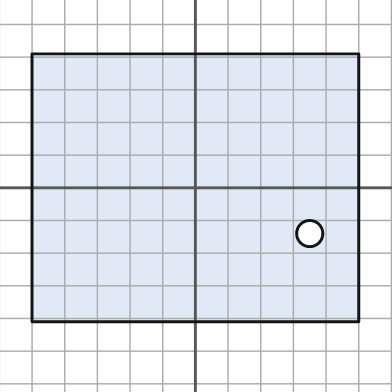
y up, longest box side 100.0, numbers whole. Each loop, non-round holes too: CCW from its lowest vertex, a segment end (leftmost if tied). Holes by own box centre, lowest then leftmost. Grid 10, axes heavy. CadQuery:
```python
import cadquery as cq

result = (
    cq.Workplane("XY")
    .moveTo(-50.0, -41.0)
    .lineTo(50.0, -41.0)
    .lineTo(50.0, 41.0)
    .lineTo(-50.0, 41.0)
    .close()
    .moveTo(35.0, -14.0)
    .circle(4.0)
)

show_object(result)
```